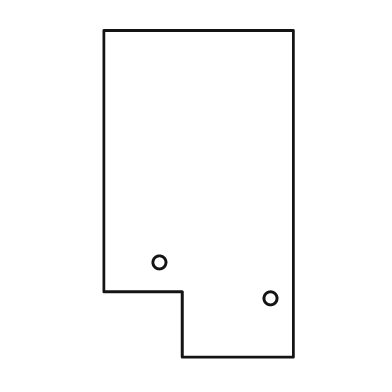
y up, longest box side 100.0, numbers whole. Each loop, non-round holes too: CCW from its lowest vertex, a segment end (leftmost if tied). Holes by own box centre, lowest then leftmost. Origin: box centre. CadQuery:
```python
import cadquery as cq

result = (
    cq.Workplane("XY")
    .moveTo(-5.0, -50.0)
    .lineTo(29.0, -50.0)
    .lineTo(29.0, 50.0)
    .lineTo(-29.0, 50.0)
    .lineTo(-29.0, -30.0)
    .lineTo(-5.0, -30.0)
    .close()
    .moveTo(22.0, -32.0)
    .circle(2.0)
    .moveTo(-12.0, -21.0)
    .circle(2.0)
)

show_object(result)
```